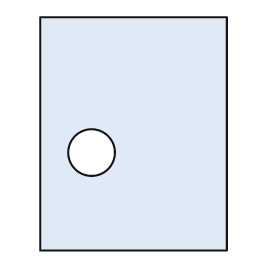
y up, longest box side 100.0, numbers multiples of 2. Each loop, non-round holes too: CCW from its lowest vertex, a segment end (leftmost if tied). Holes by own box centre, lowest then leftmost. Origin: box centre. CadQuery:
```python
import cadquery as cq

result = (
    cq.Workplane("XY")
    .moveTo(-40.0, -50.0)
    .lineTo(40.0, -50.0)
    .lineTo(40.0, 50.0)
    .lineTo(-40.0, 50.0)
    .close()
    .moveTo(-18.0, -8.0)
    .circle(10.0)
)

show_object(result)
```